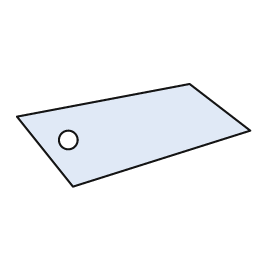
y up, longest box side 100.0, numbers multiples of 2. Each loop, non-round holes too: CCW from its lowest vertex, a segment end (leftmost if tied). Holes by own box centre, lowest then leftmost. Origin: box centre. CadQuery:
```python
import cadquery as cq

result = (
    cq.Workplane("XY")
    .moveTo(-26.0, -22.0)
    .lineTo(50.0, 2.0)
    .lineTo(24.0, 22.0)
    .lineTo(-50.0, 8.0)
    .close()
    .moveTo(-28.0, -2.0)
    .circle(4.0)
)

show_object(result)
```